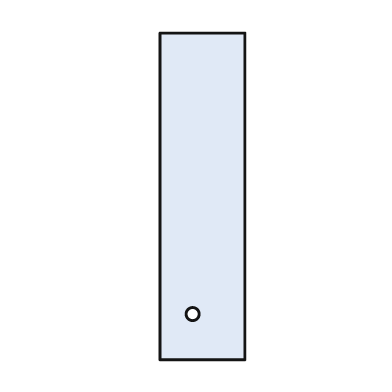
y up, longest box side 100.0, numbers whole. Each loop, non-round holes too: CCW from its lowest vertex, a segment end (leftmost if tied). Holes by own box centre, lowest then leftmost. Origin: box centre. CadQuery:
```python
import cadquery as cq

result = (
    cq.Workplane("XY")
    .moveTo(-13.0, -50.0)
    .lineTo(13.0, -50.0)
    .lineTo(13.0, 50.0)
    .lineTo(-13.0, 50.0)
    .close()
    .moveTo(-3.0, -36.0)
    .circle(2.0)
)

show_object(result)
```